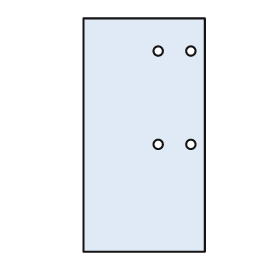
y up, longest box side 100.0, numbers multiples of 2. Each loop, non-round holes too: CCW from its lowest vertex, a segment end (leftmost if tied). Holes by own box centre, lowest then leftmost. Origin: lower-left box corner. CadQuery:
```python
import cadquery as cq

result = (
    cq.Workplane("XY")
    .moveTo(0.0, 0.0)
    .lineTo(52.0, 0.0)
    .lineTo(52.0, 100.0)
    .lineTo(0.0, 100.0)
    .close()
    .moveTo(32.0, 46.0)
    .circle(2.0)
    .moveTo(46.0, 46.0)
    .circle(2.0)
    .moveTo(32.0, 86.0)
    .circle(2.0)
    .moveTo(46.0, 86.0)
    .circle(2.0)
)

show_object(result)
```